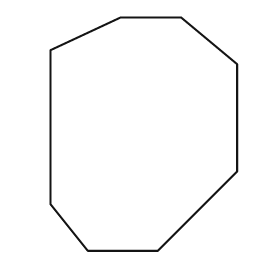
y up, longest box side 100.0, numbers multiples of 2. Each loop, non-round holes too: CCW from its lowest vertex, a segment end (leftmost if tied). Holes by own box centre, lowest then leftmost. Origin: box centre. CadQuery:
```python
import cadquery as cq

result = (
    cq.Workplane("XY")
    .moveTo(-24.0, -50.0)
    .lineTo(6.0, -50.0)
    .lineTo(40.0, -16.0)
    .lineTo(40.0, 30.0)
    .lineTo(16.0, 50.0)
    .lineTo(-10.0, 50.0)
    .lineTo(-40.0, 36.0)
    .lineTo(-40.0, -30.0)
    .close()
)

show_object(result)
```